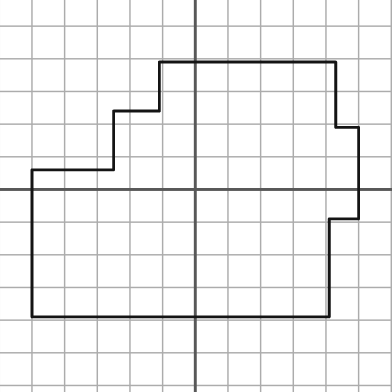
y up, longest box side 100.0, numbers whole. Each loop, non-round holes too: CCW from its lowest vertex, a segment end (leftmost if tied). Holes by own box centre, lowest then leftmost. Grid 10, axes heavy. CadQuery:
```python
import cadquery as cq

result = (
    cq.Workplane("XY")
    .moveTo(-50.0, -39.0)
    .lineTo(41.0, -39.0)
    .lineTo(41.0, -9.0)
    .lineTo(50.0, -9.0)
    .lineTo(50.0, 19.0)
    .lineTo(43.0, 19.0)
    .lineTo(43.0, 39.0)
    .lineTo(-11.0, 39.0)
    .lineTo(-11.0, 24.0)
    .lineTo(-25.0, 24.0)
    .lineTo(-25.0, 6.0)
    .lineTo(-50.0, 6.0)
    .close()
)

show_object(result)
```